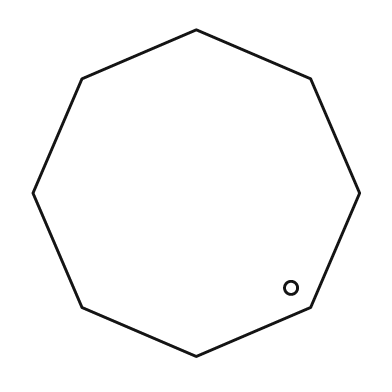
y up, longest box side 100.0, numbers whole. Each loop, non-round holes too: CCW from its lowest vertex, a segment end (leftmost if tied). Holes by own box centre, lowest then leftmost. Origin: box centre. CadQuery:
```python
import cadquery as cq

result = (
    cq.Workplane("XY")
    .moveTo(0.0, -50.0)
    .lineTo(35.0, -35.0)
    .lineTo(50.0, 0.0)
    .lineTo(35.0, 35.0)
    .lineTo(0.0, 50.0)
    .lineTo(-35.0, 35.0)
    .lineTo(-50.0, 0.0)
    .lineTo(-35.0, -35.0)
    .close()
    .moveTo(29.0, -29.0)
    .circle(2.0)
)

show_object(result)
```